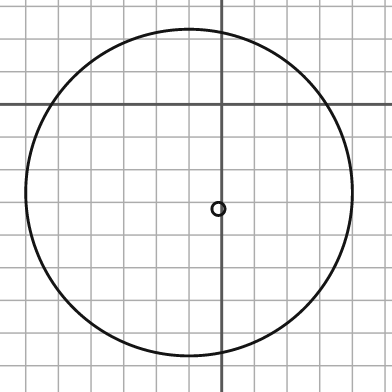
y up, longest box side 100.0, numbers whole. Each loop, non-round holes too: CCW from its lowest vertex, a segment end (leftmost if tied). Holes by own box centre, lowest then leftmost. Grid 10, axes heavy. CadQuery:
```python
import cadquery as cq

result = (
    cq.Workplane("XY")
    .moveTo(-10.0, -27.0)
    .circle(50.0)
    .moveTo(-1.0, -32.0)
    .circle(2.0)
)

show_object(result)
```